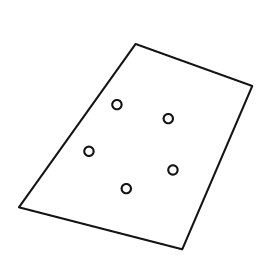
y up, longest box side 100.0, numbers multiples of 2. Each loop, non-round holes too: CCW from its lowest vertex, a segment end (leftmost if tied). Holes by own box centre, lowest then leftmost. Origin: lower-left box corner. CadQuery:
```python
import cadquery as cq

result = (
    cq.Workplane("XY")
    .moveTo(70.0, 0.0)
    .lineTo(100.0, 70.0)
    .lineTo(50.0, 88.0)
    .lineTo(0.0, 18.0)
    .close()
    .moveTo(46.0, 26.0)
    .circle(2.0)
    .moveTo(66.0, 34.0)
    .circle(2.0)
    .moveTo(30.0, 42.0)
    .circle(2.0)
    .moveTo(64.0, 56.0)
    .circle(2.0)
    .moveTo(42.0, 62.0)
    .circle(2.0)
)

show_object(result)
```